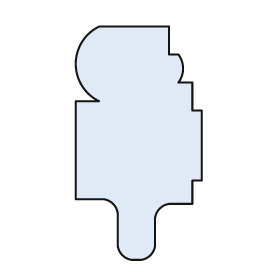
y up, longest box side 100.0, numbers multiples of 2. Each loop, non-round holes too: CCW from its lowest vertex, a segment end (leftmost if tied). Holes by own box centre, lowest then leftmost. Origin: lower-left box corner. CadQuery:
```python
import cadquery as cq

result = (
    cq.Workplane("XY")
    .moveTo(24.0, 0.0)
    .lineTo(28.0, 0.0)
    .threePointArc((32.0, 2.0), (34.0, 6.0))
    .lineTo(34.0, 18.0)
    .threePointArc((36.0, 22.0), (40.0, 24.0))
    .lineTo(50.0, 24.0)
    .lineTo(50.0, 34.0)
    .lineTo(54.0, 34.0)
    .lineTo(54.0, 64.0)
    .lineTo(50.0, 64.0)
    .lineTo(50.0, 76.0)
    .lineTo(44.0, 76.0)
    .threePointArc((46.0, 82.0), (44.0, 88.0))
    .lineTo(40.0, 88.0)
    .lineTo(40.0, 100.0)
    .lineTo(10.0, 100.0)
    .threePointArc((0.0, 84.0), (10.0, 68.0))
    .lineTo(0.0, 68.0)
    .lineTo(0.0, 26.0)
    .lineTo(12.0, 26.0)
    .threePointArc((16.0, 24.0), (18.0, 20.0))
    .lineTo(18.0, 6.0)
    .threePointArc((20.0, 2.0), (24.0, 0.0))
    .close()
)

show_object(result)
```